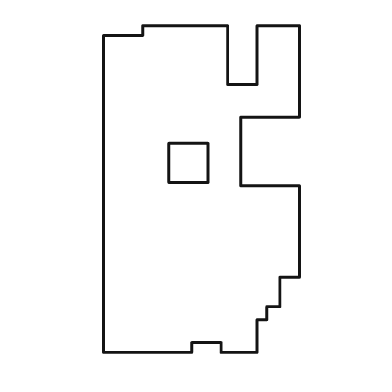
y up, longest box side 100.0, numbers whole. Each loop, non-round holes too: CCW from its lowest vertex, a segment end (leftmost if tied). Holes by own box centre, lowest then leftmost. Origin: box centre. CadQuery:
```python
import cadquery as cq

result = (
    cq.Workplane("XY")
    .moveTo(-30.0, -50.0)
    .lineTo(-3.0, -50.0)
    .lineTo(-3.0, -47.0)
    .lineTo(6.0, -47.0)
    .lineTo(6.0, -50.0)
    .lineTo(17.0, -50.0)
    .lineTo(17.0, -40.0)
    .lineTo(20.0, -40.0)
    .lineTo(20.0, -36.0)
    .lineTo(24.0, -36.0)
    .lineTo(24.0, -27.0)
    .lineTo(30.0, -27.0)
    .lineTo(30.0, 1.0)
    .lineTo(12.0, 1.0)
    .lineTo(12.0, 22.0)
    .lineTo(30.0, 22.0)
    .lineTo(30.0, 50.0)
    .lineTo(17.0, 50.0)
    .lineTo(17.0, 32.0)
    .lineTo(8.0, 32.0)
    .lineTo(8.0, 50.0)
    .lineTo(-18.0, 50.0)
    .lineTo(-18.0, 47.0)
    .lineTo(-30.0, 47.0)
    .close()
    .moveTo(-10.0, 2.0)
    .lineTo(2.0, 2.0)
    .lineTo(2.0, 14.0)
    .lineTo(-10.0, 14.0)
    .close()
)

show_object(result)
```